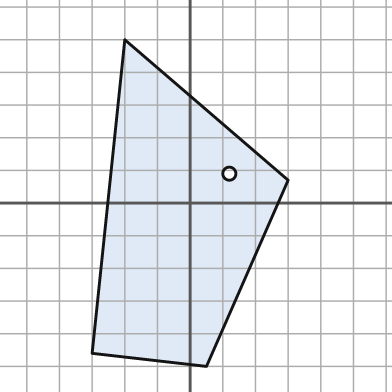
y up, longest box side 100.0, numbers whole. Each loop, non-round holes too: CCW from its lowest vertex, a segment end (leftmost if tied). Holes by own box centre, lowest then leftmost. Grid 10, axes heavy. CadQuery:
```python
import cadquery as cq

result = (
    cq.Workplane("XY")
    .moveTo(5.0, -50.0)
    .lineTo(30.0, 7.0)
    .lineTo(-20.0, 50.0)
    .lineTo(-30.0, -46.0)
    .close()
    .moveTo(12.0, 9.0)
    .circle(2.0)
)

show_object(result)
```